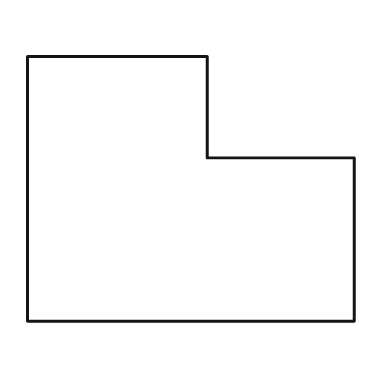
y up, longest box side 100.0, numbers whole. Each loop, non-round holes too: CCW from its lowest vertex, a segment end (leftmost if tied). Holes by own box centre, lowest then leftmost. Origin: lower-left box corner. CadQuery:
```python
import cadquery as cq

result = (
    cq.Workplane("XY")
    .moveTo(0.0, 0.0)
    .lineTo(100.0, 0.0)
    .lineTo(100.0, 50.0)
    .lineTo(55.0, 50.0)
    .lineTo(55.0, 81.0)
    .lineTo(0.0, 81.0)
    .close()
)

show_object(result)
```